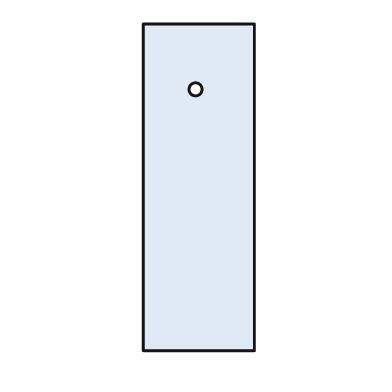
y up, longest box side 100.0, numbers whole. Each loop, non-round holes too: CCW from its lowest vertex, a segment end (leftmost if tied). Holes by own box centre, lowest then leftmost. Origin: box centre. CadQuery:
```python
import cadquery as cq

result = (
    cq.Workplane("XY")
    .moveTo(-17.0, -50.0)
    .lineTo(17.0, -50.0)
    .lineTo(17.0, 50.0)
    .lineTo(-17.0, 50.0)
    .close()
    .moveTo(-1.0, 30.0)
    .circle(2.0)
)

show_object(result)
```